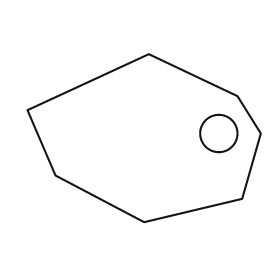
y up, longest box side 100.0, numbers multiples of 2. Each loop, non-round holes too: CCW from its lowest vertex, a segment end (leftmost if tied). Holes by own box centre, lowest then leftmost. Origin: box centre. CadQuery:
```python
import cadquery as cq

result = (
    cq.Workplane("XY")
    .moveTo(0.0, -36.0)
    .lineTo(42.0, -26.0)
    .lineTo(50.0, 2.0)
    .lineTo(40.0, 18.0)
    .lineTo(2.0, 36.0)
    .lineTo(-50.0, 12.0)
    .lineTo(-38.0, -16.0)
    .close()
    .moveTo(32.0, 2.0)
    .circle(8.0)
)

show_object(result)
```